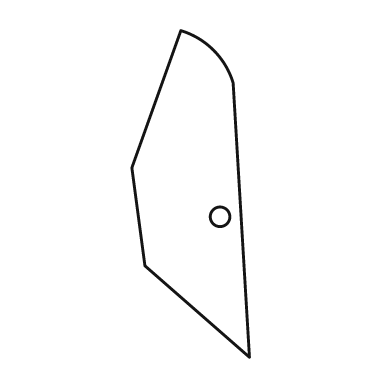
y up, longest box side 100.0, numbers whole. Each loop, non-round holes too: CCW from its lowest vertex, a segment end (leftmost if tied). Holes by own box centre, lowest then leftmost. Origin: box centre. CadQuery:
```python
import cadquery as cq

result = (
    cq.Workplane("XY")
    .moveTo(18.0, -50.0)
    .lineTo(13.0, 34.0)
    .threePointArc((7.0, 44.0), (-3.0, 50.0))
    .lineTo(-18.0, 8.0)
    .lineTo(-14.0, -22.0)
    .close()
    .moveTo(9.0, -7.0)
    .circle(3.0)
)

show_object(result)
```